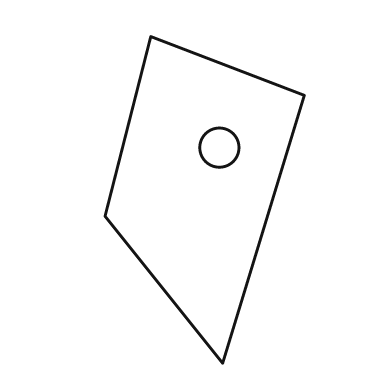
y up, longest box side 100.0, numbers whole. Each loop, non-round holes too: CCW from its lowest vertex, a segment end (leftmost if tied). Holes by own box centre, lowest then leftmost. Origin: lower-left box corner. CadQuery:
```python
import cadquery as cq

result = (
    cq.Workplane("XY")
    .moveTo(36.0, 0.0)
    .lineTo(61.0, 82.0)
    .lineTo(14.0, 100.0)
    .lineTo(0.0, 45.0)
    .close()
    .moveTo(35.0, 66.0)
    .circle(6.0)
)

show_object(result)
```